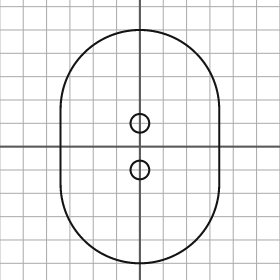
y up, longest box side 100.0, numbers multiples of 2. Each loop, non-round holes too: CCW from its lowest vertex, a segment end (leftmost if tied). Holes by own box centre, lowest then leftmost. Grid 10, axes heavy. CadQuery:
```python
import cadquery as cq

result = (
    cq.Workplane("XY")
    .moveTo(-34.0, -16.0)
    .threePointArc((0.0, -50.0), (34.0, -16.0))
    .lineTo(34.0, 16.0)
    .threePointArc((0.0, 50.0), (-34.0, 16.0))
    .close()
    .moveTo(0.0, -10.0)
    .circle(4.0)
    .moveTo(0.0, 10.0)
    .circle(4.0)
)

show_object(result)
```